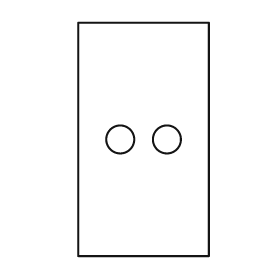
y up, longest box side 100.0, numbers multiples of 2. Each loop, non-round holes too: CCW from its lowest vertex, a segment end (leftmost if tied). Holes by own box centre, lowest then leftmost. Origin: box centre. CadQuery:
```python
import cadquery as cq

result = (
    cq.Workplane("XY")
    .moveTo(-28.0, -50.0)
    .lineTo(28.0, -50.0)
    .lineTo(28.0, 50.0)
    .lineTo(-28.0, 50.0)
    .close()
    .moveTo(-10.0, 0.0)
    .circle(6.0)
    .moveTo(10.0, 0.0)
    .circle(6.0)
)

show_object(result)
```